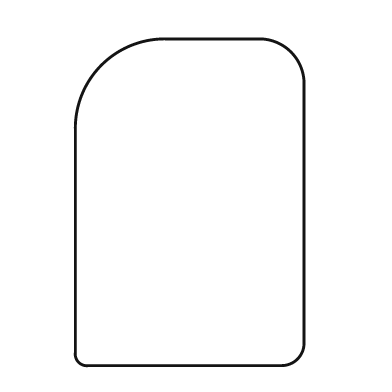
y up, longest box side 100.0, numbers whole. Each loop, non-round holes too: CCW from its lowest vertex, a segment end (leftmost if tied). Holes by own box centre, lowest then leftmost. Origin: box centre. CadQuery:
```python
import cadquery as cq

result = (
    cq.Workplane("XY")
    .moveTo(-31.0, -50.0)
    .lineTo(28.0, -50.0)
    .threePointArc((33.0, -48.0), (35.0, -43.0))
    .lineTo(35.0, 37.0)
    .threePointArc((31.0, 46.0), (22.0, 50.0))
    .lineTo(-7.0, 50.0)
    .threePointArc((-27.0, 42.0), (-35.0, 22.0))
    .lineTo(-35.0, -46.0)
    .threePointArc((-34.0, -49.0), (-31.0, -50.0))
    .close()
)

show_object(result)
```